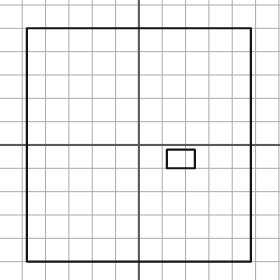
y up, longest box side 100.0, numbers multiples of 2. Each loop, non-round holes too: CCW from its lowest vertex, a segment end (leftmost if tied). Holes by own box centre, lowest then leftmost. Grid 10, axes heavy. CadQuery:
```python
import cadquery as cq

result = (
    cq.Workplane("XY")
    .moveTo(-48.0, -50.0)
    .lineTo(48.0, -50.0)
    .lineTo(48.0, 50.0)
    .lineTo(-48.0, 50.0)
    .close()
    .moveTo(12.0, -10.0)
    .lineTo(24.0, -10.0)
    .lineTo(24.0, -2.0)
    .lineTo(12.0, -2.0)
    .close()
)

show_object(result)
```